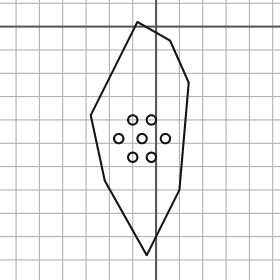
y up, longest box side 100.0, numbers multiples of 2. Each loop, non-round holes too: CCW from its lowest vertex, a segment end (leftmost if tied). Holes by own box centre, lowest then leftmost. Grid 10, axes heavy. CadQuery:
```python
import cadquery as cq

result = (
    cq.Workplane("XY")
    .moveTo(-4.0, -98.0)
    .lineTo(10.0, -70.0)
    .lineTo(14.0, -24.0)
    .lineTo(6.0, -6.0)
    .lineTo(-8.0, 2.0)
    .lineTo(-28.0, -38.0)
    .lineTo(-22.0, -66.0)
    .close()
    .moveTo(-10.0, -56.0)
    .circle(2.0)
    .moveTo(-2.0, -56.0)
    .circle(2.0)
    .moveTo(-16.0, -48.0)
    .circle(2.0)
    .moveTo(-6.0, -48.0)
    .circle(2.0)
    .moveTo(4.0, -48.0)
    .circle(2.0)
    .moveTo(-10.0, -40.0)
    .circle(2.0)
    .moveTo(-2.0, -40.0)
    .circle(2.0)
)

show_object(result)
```